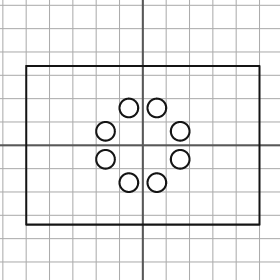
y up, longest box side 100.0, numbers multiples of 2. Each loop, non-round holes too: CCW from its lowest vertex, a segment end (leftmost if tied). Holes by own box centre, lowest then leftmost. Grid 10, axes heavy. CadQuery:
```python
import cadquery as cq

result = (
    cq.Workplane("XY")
    .moveTo(-50.0, -34.0)
    .lineTo(50.0, -34.0)
    .lineTo(50.0, 34.0)
    .lineTo(-50.0, 34.0)
    .close()
    .moveTo(-6.0, -16.0)
    .circle(4.0)
    .moveTo(6.0, -16.0)
    .circle(4.0)
    .moveTo(-16.0, -6.0)
    .circle(4.0)
    .moveTo(16.0, -6.0)
    .circle(4.0)
    .moveTo(-16.0, 6.0)
    .circle(4.0)
    .moveTo(16.0, 6.0)
    .circle(4.0)
    .moveTo(-6.0, 16.0)
    .circle(4.0)
    .moveTo(6.0, 16.0)
    .circle(4.0)
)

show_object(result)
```